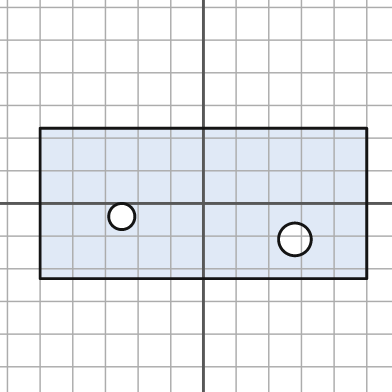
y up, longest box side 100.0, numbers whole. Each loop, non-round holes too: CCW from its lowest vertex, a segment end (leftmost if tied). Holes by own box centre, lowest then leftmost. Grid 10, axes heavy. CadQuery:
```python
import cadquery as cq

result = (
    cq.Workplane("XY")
    .moveTo(-50.0, -23.0)
    .lineTo(50.0, -23.0)
    .lineTo(50.0, 23.0)
    .lineTo(-50.0, 23.0)
    .close()
    .moveTo(28.0, -11.0)
    .circle(5.0)
    .moveTo(-25.0, -4.0)
    .circle(4.0)
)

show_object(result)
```